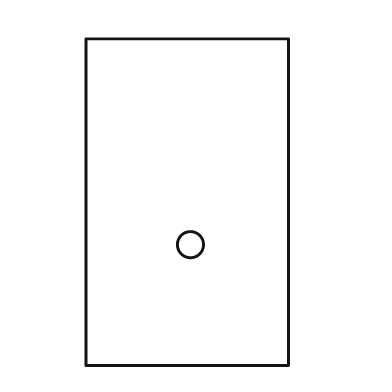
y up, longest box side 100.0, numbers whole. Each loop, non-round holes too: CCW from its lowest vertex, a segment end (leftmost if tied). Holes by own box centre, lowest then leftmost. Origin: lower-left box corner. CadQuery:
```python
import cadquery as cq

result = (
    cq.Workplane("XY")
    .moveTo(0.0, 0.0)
    .lineTo(62.0, 0.0)
    .lineTo(62.0, 100.0)
    .lineTo(0.0, 100.0)
    .close()
    .moveTo(32.0, 37.0)
    .circle(4.0)
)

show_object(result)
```